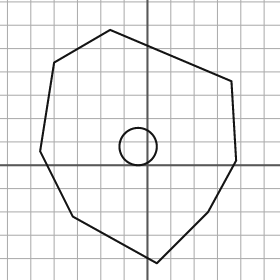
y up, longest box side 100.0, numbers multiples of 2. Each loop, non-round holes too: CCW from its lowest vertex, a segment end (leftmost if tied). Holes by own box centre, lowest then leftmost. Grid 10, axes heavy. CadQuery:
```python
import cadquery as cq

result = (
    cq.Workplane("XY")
    .moveTo(4.0, -42.0)
    .lineTo(26.0, -20.0)
    .lineTo(38.0, 2.0)
    .lineTo(36.0, 36.0)
    .lineTo(-16.0, 58.0)
    .lineTo(-40.0, 44.0)
    .lineTo(-46.0, 6.0)
    .lineTo(-32.0, -22.0)
    .close()
    .moveTo(-4.0, 8.0)
    .circle(8.0)
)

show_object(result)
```